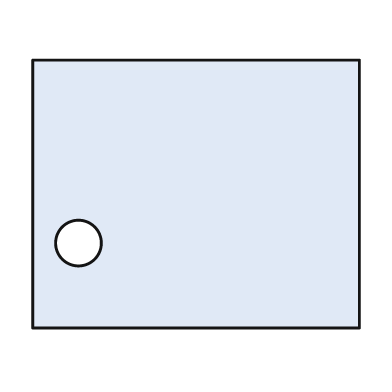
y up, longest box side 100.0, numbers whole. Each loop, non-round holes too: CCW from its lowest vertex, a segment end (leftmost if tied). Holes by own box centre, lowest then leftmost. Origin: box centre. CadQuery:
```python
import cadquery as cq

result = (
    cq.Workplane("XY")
    .moveTo(-50.0, -41.0)
    .lineTo(50.0, -41.0)
    .lineTo(50.0, 41.0)
    .lineTo(-50.0, 41.0)
    .close()
    .moveTo(-36.0, -15.0)
    .circle(7.0)
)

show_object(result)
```